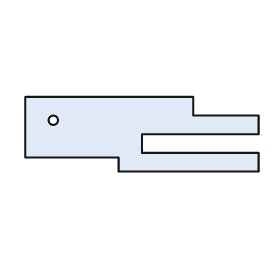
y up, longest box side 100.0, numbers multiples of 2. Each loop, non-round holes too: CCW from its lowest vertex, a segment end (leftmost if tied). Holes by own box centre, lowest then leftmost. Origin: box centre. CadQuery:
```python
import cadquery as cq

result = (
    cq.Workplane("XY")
    .moveTo(-10.0, -16.0)
    .lineTo(50.0, -16.0)
    .lineTo(50.0, -8.0)
    .lineTo(0.0, -8.0)
    .lineTo(0.0, 0.0)
    .lineTo(50.0, 0.0)
    .lineTo(50.0, 8.0)
    .lineTo(22.0, 8.0)
    .lineTo(22.0, 16.0)
    .lineTo(-50.0, 16.0)
    .lineTo(-50.0, -10.0)
    .lineTo(-10.0, -10.0)
    .close()
    .moveTo(-38.0, 6.0)
    .circle(2.0)
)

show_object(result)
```